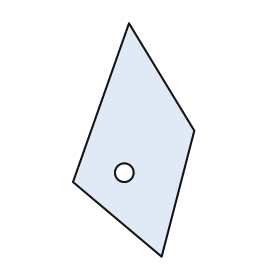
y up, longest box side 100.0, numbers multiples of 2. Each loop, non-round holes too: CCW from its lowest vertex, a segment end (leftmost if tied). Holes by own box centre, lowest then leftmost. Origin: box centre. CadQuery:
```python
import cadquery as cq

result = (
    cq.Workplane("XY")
    .moveTo(12.0, -50.0)
    .lineTo(26.0, 4.0)
    .lineTo(-2.0, 50.0)
    .lineTo(-26.0, -18.0)
    .close()
    .moveTo(-4.0, -14.0)
    .circle(4.0)
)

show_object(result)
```